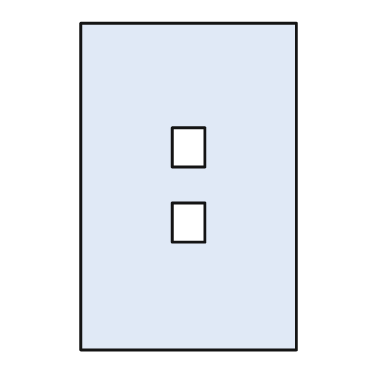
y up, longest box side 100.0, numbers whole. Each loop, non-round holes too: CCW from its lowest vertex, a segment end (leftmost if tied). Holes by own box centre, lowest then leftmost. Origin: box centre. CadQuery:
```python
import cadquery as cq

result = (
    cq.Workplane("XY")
    .moveTo(-33.0, -50.0)
    .lineTo(33.0, -50.0)
    .lineTo(33.0, 50.0)
    .lineTo(-33.0, 50.0)
    .close()
    .moveTo(-5.0, -17.0)
    .lineTo(5.0, -17.0)
    .lineTo(5.0, -5.0)
    .lineTo(-5.0, -5.0)
    .close()
    .moveTo(-5.0, 6.0)
    .lineTo(5.0, 6.0)
    .lineTo(5.0, 18.0)
    .lineTo(-5.0, 18.0)
    .close()
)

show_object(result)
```